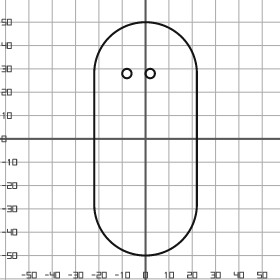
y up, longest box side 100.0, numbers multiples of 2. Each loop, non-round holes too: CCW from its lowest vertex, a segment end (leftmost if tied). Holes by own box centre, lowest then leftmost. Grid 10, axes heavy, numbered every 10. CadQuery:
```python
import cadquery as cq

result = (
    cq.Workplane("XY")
    .moveTo(-22.0, -28.0)
    .threePointArc((0.0, -50.0), (22.0, -28.0))
    .lineTo(22.0, 28.0)
    .threePointArc((0.0, 50.0), (-22.0, 28.0))
    .close()
    .moveTo(-8.0, 28.0)
    .circle(2.0)
    .moveTo(2.0, 28.0)
    .circle(2.0)
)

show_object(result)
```